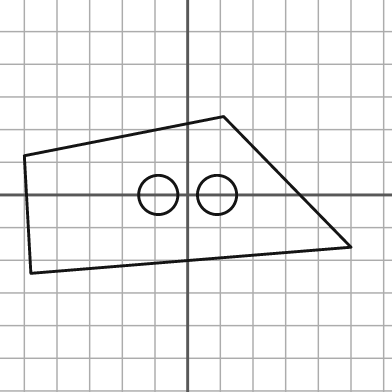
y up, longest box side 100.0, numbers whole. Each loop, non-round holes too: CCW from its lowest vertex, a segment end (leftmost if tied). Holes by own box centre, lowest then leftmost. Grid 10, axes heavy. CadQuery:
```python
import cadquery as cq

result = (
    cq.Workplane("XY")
    .moveTo(-48.0, -24.0)
    .lineTo(50.0, -16.0)
    .lineTo(11.0, 24.0)
    .lineTo(-50.0, 12.0)
    .close()
    .moveTo(-9.0, 0.0)
    .circle(6.0)
    .moveTo(9.0, 0.0)
    .circle(6.0)
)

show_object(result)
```